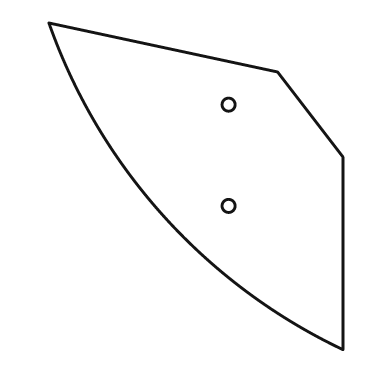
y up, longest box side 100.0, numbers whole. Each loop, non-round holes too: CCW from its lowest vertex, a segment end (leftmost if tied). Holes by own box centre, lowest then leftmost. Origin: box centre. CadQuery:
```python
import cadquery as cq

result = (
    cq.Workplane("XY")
    .moveTo(45.0, -50.0)
    .lineTo(45.0, 9.0)
    .lineTo(25.0, 35.0)
    .lineTo(-45.0, 50.0)
    .threePointArc((-10.0, -9.0), (45.0, -50.0))
    .close()
    .moveTo(10.0, -6.0)
    .circle(2.0)
    .moveTo(10.0, 25.0)
    .circle(2.0)
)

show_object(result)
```